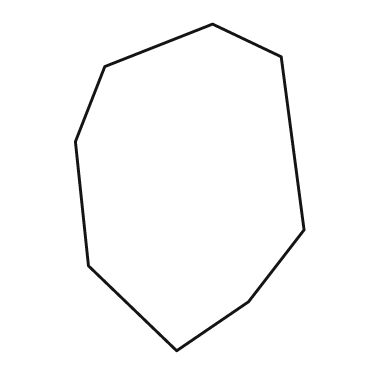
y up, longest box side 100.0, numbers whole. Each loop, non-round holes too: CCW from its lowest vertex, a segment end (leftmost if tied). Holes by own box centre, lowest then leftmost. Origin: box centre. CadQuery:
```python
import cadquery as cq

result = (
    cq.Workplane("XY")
    .moveTo(-4.0, -50.0)
    .lineTo(18.0, -35.0)
    .lineTo(35.0, -13.0)
    .lineTo(28.0, 40.0)
    .lineTo(7.0, 50.0)
    .lineTo(-26.0, 37.0)
    .lineTo(-35.0, 14.0)
    .lineTo(-31.0, -24.0)
    .close()
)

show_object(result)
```